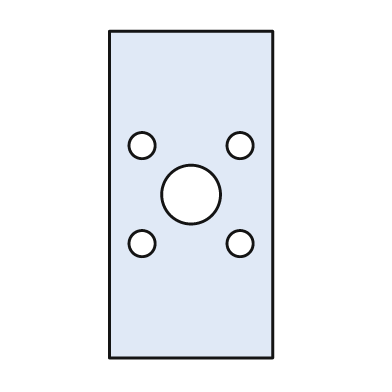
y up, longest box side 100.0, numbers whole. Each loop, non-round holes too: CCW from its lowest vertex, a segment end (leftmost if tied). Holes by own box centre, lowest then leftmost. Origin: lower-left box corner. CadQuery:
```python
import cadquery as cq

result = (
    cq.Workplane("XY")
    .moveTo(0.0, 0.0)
    .lineTo(50.0, 0.0)
    .lineTo(50.0, 100.0)
    .lineTo(0.0, 100.0)
    .close()
    .moveTo(10.0, 35.0)
    .circle(4.0)
    .moveTo(40.0, 35.0)
    .circle(4.0)
    .moveTo(25.0, 50.0)
    .circle(9.0)
    .moveTo(10.0, 65.0)
    .circle(4.0)
    .moveTo(40.0, 65.0)
    .circle(4.0)
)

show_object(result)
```